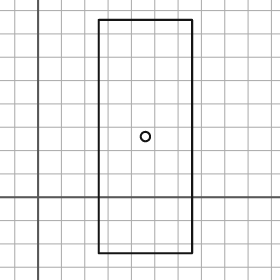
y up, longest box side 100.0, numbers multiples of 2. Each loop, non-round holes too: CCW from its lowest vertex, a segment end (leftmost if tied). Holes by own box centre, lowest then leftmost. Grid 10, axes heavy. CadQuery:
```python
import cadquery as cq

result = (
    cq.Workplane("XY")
    .moveTo(26.0, -24.0)
    .lineTo(66.0, -24.0)
    .lineTo(66.0, 76.0)
    .lineTo(26.0, 76.0)
    .close()
    .moveTo(46.0, 26.0)
    .circle(2.0)
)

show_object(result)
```